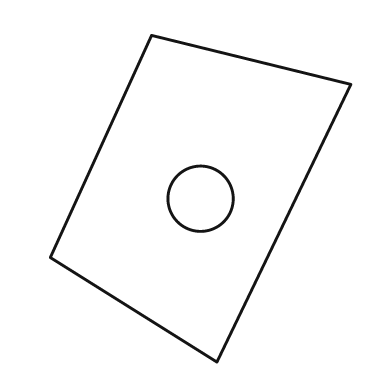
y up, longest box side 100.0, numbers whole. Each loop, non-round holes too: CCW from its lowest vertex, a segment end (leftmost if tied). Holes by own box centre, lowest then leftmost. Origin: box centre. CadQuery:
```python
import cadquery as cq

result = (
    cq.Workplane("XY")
    .moveTo(5.0, -50.0)
    .lineTo(46.0, 35.0)
    .lineTo(-15.0, 50.0)
    .lineTo(-46.0, -18.0)
    .close()
    .moveTo(0.0, 0.0)
    .circle(10.0)
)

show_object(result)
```